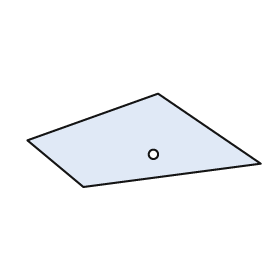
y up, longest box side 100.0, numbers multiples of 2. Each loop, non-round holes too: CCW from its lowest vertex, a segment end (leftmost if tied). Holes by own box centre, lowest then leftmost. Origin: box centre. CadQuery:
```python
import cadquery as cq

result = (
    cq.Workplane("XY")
    .moveTo(-26.0, -20.0)
    .lineTo(50.0, -10.0)
    .lineTo(6.0, 20.0)
    .lineTo(-50.0, 0.0)
    .close()
    .moveTo(4.0, -6.0)
    .circle(2.0)
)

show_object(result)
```